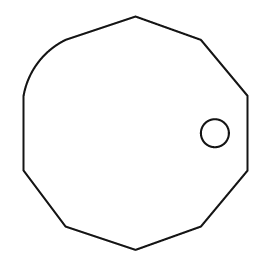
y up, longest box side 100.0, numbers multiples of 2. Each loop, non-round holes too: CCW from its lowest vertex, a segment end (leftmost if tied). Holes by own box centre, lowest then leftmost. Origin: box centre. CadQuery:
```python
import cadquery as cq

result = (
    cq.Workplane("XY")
    .moveTo(0.0, -50.0)
    .lineTo(28.0, -40.0)
    .lineTo(48.0, -16.0)
    .lineTo(48.0, 16.0)
    .lineTo(28.0, 40.0)
    .lineTo(0.0, 50.0)
    .lineTo(-30.0, 40.0)
    .threePointArc((-42.0, 30.0), (-48.0, 16.0))
    .lineTo(-48.0, -16.0)
    .lineTo(-30.0, -40.0)
    .close()
    .moveTo(34.0, 0.0)
    .circle(6.0)
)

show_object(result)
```